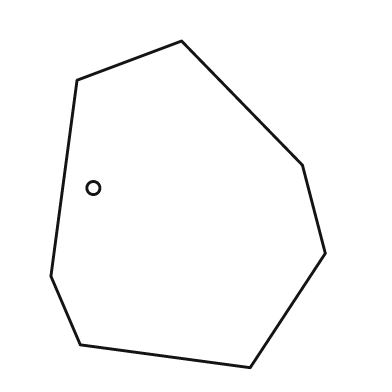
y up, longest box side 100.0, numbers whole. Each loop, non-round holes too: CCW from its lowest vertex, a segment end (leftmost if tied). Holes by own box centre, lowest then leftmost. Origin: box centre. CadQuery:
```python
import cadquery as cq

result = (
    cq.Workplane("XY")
    .moveTo(19.0, -50.0)
    .lineTo(42.0, -15.0)
    .lineTo(35.0, 12.0)
    .lineTo(-2.0, 50.0)
    .lineTo(-34.0, 38.0)
    .lineTo(-42.0, -22.0)
    .lineTo(-33.0, -43.0)
    .close()
    .moveTo(-29.0, 5.0)
    .circle(2.0)
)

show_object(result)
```